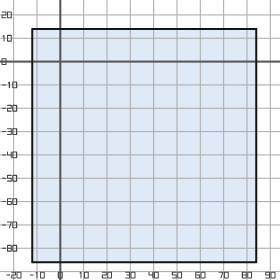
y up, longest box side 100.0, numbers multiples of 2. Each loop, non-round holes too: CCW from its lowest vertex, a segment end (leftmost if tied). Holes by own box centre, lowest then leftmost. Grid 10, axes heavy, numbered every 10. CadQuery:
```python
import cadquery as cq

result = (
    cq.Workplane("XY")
    .moveTo(-12.0, -86.0)
    .lineTo(84.0, -86.0)
    .lineTo(84.0, 14.0)
    .lineTo(-12.0, 14.0)
    .close()
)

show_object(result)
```